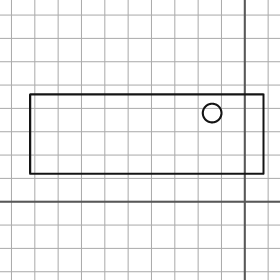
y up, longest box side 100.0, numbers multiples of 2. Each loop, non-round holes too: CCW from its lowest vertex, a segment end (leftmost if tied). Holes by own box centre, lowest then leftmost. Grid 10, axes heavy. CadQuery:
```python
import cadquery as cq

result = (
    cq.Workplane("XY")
    .moveTo(-92.0, 12.0)
    .lineTo(8.0, 12.0)
    .lineTo(8.0, 46.0)
    .lineTo(-92.0, 46.0)
    .close()
    .moveTo(-14.0, 38.0)
    .circle(4.0)
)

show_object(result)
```